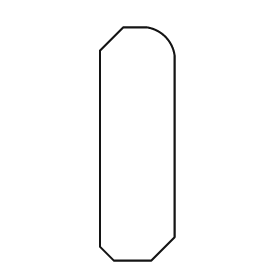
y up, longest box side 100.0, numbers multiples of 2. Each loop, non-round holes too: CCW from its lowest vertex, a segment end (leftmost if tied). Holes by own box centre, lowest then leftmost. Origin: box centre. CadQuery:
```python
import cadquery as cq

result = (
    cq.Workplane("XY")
    .moveTo(-10.0, -50.0)
    .lineTo(6.0, -50.0)
    .lineTo(16.0, -40.0)
    .lineTo(16.0, 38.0)
    .threePointArc((12.0, 46.0), (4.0, 50.0))
    .lineTo(-6.0, 50.0)
    .lineTo(-16.0, 40.0)
    .lineTo(-16.0, -44.0)
    .close()
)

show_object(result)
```